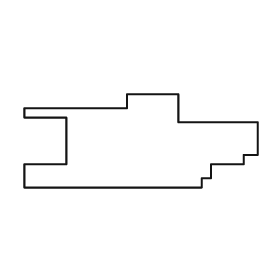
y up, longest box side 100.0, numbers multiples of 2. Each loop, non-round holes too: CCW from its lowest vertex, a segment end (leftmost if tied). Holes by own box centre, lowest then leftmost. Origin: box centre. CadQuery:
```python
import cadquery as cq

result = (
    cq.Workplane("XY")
    .moveTo(-50.0, -20.0)
    .lineTo(26.0, -20.0)
    .lineTo(26.0, -16.0)
    .lineTo(30.0, -16.0)
    .lineTo(30.0, -10.0)
    .lineTo(44.0, -10.0)
    .lineTo(44.0, -6.0)
    .lineTo(50.0, -6.0)
    .lineTo(50.0, 8.0)
    .lineTo(16.0, 8.0)
    .lineTo(16.0, 20.0)
    .lineTo(-6.0, 20.0)
    .lineTo(-6.0, 14.0)
    .lineTo(-50.0, 14.0)
    .lineTo(-50.0, 10.0)
    .lineTo(-32.0, 10.0)
    .lineTo(-32.0, -10.0)
    .lineTo(-50.0, -10.0)
    .close()
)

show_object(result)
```